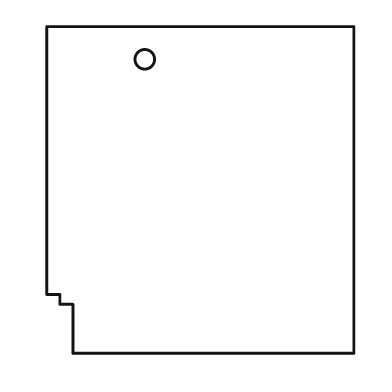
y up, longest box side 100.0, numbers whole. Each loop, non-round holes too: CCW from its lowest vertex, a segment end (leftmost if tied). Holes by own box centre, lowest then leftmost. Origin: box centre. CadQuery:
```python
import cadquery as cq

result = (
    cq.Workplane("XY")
    .moveTo(-39.0, -50.0)
    .lineTo(47.0, -50.0)
    .lineTo(47.0, 50.0)
    .lineTo(-47.0, 50.0)
    .lineTo(-47.0, -32.0)
    .lineTo(-43.0, -32.0)
    .lineTo(-43.0, -35.0)
    .lineTo(-39.0, -35.0)
    .close()
    .moveTo(-17.0, 40.0)
    .circle(3.0)
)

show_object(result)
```